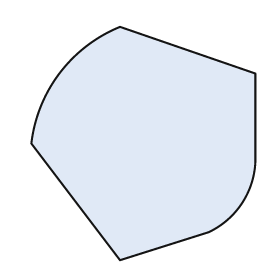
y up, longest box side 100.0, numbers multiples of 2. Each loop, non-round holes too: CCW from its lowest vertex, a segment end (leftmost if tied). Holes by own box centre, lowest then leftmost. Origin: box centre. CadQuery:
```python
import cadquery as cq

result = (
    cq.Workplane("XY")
    .moveTo(-10.0, -50.0)
    .lineTo(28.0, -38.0)
    .threePointArc((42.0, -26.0), (48.0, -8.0))
    .lineTo(48.0, 30.0)
    .lineTo(-10.0, 50.0)
    .threePointArc((-36.0, 30.0), (-48.0, 0.0))
    .close()
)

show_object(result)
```